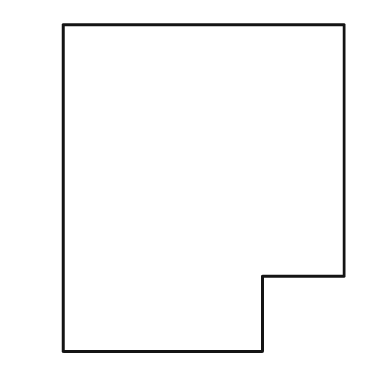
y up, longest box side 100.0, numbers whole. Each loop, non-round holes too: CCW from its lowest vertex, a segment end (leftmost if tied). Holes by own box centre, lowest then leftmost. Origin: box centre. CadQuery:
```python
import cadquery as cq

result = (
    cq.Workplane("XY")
    .moveTo(-43.0, -50.0)
    .lineTo(18.0, -50.0)
    .lineTo(18.0, -27.0)
    .lineTo(43.0, -27.0)
    .lineTo(43.0, 50.0)
    .lineTo(-43.0, 50.0)
    .close()
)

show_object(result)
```